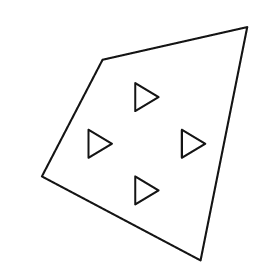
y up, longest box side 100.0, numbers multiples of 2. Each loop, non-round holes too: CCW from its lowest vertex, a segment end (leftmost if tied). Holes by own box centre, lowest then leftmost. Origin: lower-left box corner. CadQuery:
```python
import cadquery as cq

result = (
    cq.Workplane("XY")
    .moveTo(68.0, 0.0)
    .lineTo(88.0, 100.0)
    .lineTo(26.0, 86.0)
    .lineTo(0.0, 36.0)
    .close()
    .moveTo(40.0, 24.0)
    .lineTo(50.0, 30.0)
    .lineTo(40.0, 36.0)
    .close()
    .moveTo(20.0, 44.0)
    .lineTo(30.0, 50.0)
    .lineTo(20.0, 56.0)
    .close()
    .moveTo(60.0, 44.0)
    .lineTo(70.0, 50.0)
    .lineTo(60.0, 56.0)
    .close()
    .moveTo(40.0, 64.0)
    .lineTo(50.0, 70.0)
    .lineTo(40.0, 76.0)
    .close()
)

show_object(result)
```